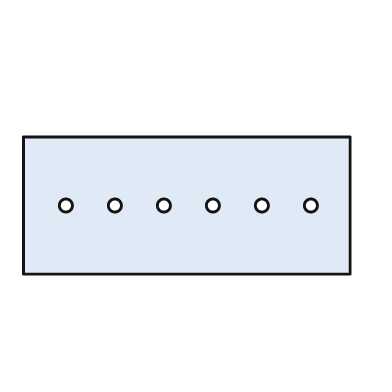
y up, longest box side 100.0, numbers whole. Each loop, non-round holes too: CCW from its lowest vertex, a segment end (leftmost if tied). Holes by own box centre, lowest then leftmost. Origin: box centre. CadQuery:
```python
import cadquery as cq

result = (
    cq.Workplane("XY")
    .moveTo(-50.0, -21.0)
    .lineTo(50.0, -21.0)
    .lineTo(50.0, 21.0)
    .lineTo(-50.0, 21.0)
    .close()
    .moveTo(-37.0, 0.0)
    .circle(2.0)
    .moveTo(-22.0, 0.0)
    .circle(2.0)
    .moveTo(-7.0, 0.0)
    .circle(2.0)
    .moveTo(8.0, 0.0)
    .circle(2.0)
    .moveTo(23.0, 0.0)
    .circle(2.0)
    .moveTo(38.0, 0.0)
    .circle(2.0)
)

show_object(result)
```